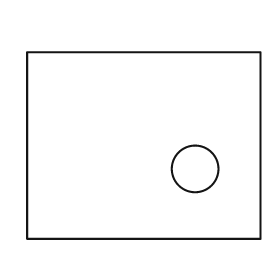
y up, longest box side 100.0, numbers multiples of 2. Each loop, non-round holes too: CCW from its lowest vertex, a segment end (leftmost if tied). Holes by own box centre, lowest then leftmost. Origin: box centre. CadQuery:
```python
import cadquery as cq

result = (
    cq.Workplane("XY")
    .moveTo(-50.0, -40.0)
    .lineTo(50.0, -40.0)
    .lineTo(50.0, 40.0)
    .lineTo(-50.0, 40.0)
    .close()
    .moveTo(22.0, -10.0)
    .circle(10.0)
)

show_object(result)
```